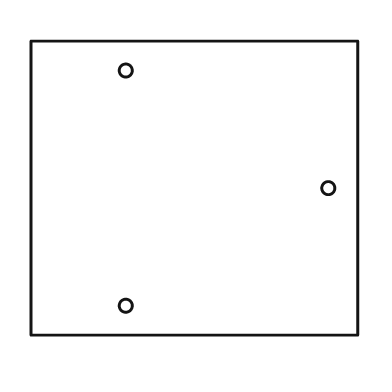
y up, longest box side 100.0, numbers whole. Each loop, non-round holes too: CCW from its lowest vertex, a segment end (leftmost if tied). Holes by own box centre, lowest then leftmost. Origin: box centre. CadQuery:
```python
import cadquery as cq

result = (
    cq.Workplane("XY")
    .moveTo(-50.0, -45.0)
    .lineTo(50.0, -45.0)
    .lineTo(50.0, 45.0)
    .lineTo(-50.0, 45.0)
    .close()
    .moveTo(-21.0, -36.0)
    .circle(2.0)
    .moveTo(41.0, 0.0)
    .circle(2.0)
    .moveTo(-21.0, 36.0)
    .circle(2.0)
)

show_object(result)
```